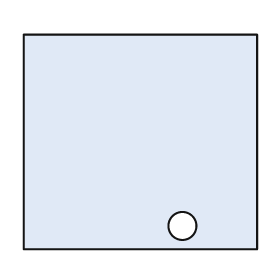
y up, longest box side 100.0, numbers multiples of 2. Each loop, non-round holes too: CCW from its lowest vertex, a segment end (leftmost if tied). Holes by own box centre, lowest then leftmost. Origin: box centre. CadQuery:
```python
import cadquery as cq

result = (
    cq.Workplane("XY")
    .moveTo(-50.0, -46.0)
    .lineTo(50.0, -46.0)
    .lineTo(50.0, 46.0)
    .lineTo(-50.0, 46.0)
    .close()
    .moveTo(18.0, -36.0)
    .circle(6.0)
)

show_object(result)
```